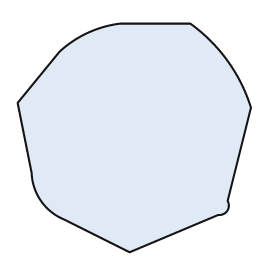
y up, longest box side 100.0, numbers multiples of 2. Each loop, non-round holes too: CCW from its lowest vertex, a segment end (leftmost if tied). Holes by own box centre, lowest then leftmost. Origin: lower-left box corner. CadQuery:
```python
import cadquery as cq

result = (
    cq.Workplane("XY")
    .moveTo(48.0, 0.0)
    .lineTo(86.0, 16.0)
    .threePointArc((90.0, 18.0), (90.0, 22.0))
    .lineTo(100.0, 62.0)
    .threePointArc((90.0, 82.0), (74.0, 98.0))
    .lineTo(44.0, 98.0)
    .threePointArc((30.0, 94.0), (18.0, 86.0))
    .lineTo(0.0, 64.0)
    .lineTo(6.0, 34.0)
    .threePointArc((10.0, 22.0), (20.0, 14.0))
    .close()
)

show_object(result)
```